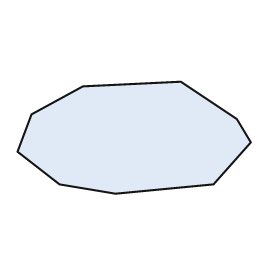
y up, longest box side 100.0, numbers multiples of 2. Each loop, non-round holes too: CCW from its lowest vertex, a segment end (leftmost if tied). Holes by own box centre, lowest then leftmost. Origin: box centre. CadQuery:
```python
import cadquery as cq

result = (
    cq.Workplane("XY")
    .moveTo(-8.0, -24.0)
    .lineTo(34.0, -20.0)
    .lineTo(50.0, -2.0)
    .lineTo(44.0, 8.0)
    .lineTo(20.0, 24.0)
    .lineTo(-22.0, 22.0)
    .lineTo(-44.0, 10.0)
    .lineTo(-50.0, -6.0)
    .lineTo(-32.0, -20.0)
    .close()
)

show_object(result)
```